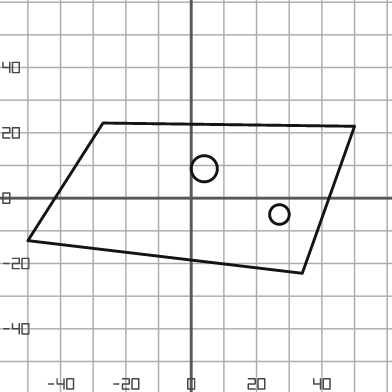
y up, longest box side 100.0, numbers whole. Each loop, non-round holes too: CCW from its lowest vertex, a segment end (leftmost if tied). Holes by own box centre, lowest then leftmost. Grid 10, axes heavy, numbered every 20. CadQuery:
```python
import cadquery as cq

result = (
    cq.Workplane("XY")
    .moveTo(34.0, -23.0)
    .lineTo(50.0, 22.0)
    .lineTo(-27.0, 23.0)
    .lineTo(-50.0, -13.0)
    .close()
    .moveTo(27.0, -5.0)
    .circle(3.0)
    .moveTo(4.0, 9.0)
    .circle(4.0)
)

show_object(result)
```